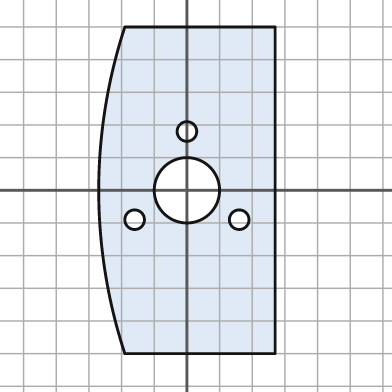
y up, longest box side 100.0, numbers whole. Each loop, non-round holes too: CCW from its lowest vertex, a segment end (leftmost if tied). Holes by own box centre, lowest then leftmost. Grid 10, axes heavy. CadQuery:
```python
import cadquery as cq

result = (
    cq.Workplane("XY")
    .moveTo(-19.0, -50.0)
    .lineTo(27.0, -50.0)
    .lineTo(27.0, 50.0)
    .lineTo(-19.0, 50.0)
    .threePointArc((-27.0, 0.0), (-19.0, -50.0))
    .close()
    .moveTo(-16.0, -9.0)
    .circle(3.0)
    .moveTo(16.0, -9.0)
    .circle(3.0)
    .moveTo(0.0, 0.0)
    .circle(10.0)
    .moveTo(0.0, 18.0)
    .circle(3.0)
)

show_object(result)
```